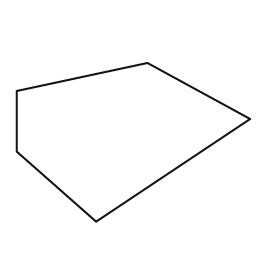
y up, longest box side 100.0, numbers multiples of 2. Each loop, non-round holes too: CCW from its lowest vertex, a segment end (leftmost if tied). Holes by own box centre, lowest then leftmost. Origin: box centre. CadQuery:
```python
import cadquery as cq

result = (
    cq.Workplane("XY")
    .moveTo(-16.0, -34.0)
    .lineTo(50.0, 10.0)
    .lineTo(6.0, 34.0)
    .lineTo(-50.0, 22.0)
    .lineTo(-50.0, -4.0)
    .close()
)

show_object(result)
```